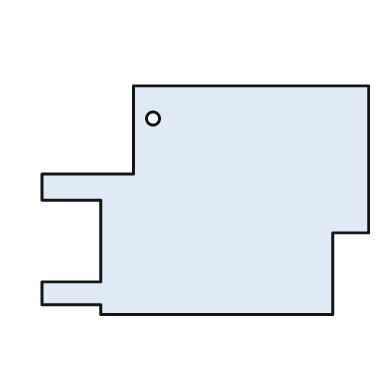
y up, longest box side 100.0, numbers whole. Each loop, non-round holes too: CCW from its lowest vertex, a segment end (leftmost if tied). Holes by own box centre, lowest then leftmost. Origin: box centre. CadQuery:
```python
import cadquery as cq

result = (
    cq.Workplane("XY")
    .moveTo(-32.0, -35.0)
    .lineTo(39.0, -35.0)
    .lineTo(39.0, -10.0)
    .lineTo(50.0, -10.0)
    .lineTo(50.0, 35.0)
    .lineTo(-22.0, 35.0)
    .lineTo(-22.0, 8.0)
    .lineTo(-50.0, 8.0)
    .lineTo(-50.0, 0.0)
    .lineTo(-32.0, 0.0)
    .lineTo(-32.0, -25.0)
    .lineTo(-50.0, -25.0)
    .lineTo(-50.0, -32.0)
    .lineTo(-32.0, -32.0)
    .close()
    .moveTo(-16.0, 25.0)
    .circle(2.0)
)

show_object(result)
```